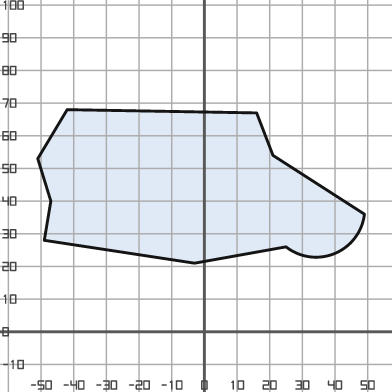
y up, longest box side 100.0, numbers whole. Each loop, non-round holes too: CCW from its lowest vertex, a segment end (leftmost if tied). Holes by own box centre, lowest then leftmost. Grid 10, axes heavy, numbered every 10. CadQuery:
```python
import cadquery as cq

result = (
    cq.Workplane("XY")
    .moveTo(-3.0, 21.0)
    .lineTo(25.0, 26.0)
    .threePointArc((40.0, 24.0), (49.0, 36.0))
    .lineTo(21.0, 54.0)
    .lineTo(16.0, 67.0)
    .lineTo(-42.0, 68.0)
    .lineTo(-51.0, 53.0)
    .lineTo(-47.0, 40.0)
    .lineTo(-49.0, 28.0)
    .close()
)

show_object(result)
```